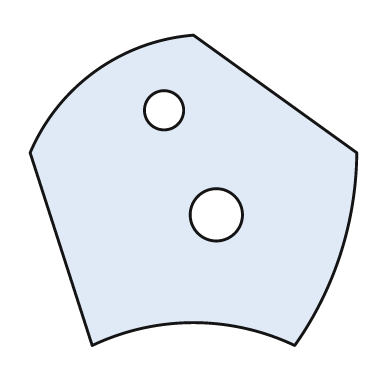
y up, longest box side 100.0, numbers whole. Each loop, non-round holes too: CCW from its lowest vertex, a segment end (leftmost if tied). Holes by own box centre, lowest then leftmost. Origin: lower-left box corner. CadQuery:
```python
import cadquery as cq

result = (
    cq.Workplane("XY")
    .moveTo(19.0, 0.0)
    .threePointArc((50.0, 7.0), (81.0, 0.0))
    .threePointArc((95.0, 28.0), (100.0, 59.0))
    .lineTo(50.0, 95.0)
    .threePointArc((20.0, 84.0), (0.0, 59.0))
    .close()
    .moveTo(57.0, 40.0)
    .circle(8.0)
    .moveTo(41.0, 72.0)
    .circle(6.0)
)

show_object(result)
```